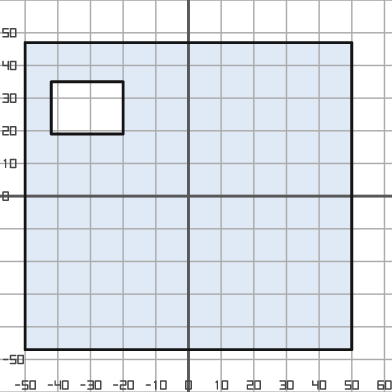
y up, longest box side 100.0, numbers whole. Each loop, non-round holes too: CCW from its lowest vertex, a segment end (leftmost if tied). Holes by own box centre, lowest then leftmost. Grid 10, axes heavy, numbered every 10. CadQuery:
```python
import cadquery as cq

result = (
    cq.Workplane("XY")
    .moveTo(-50.0, -47.0)
    .lineTo(50.0, -47.0)
    .lineTo(50.0, 47.0)
    .lineTo(-50.0, 47.0)
    .close()
    .moveTo(-42.0, 19.0)
    .lineTo(-20.0, 19.0)
    .lineTo(-20.0, 35.0)
    .lineTo(-42.0, 35.0)
    .close()
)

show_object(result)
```